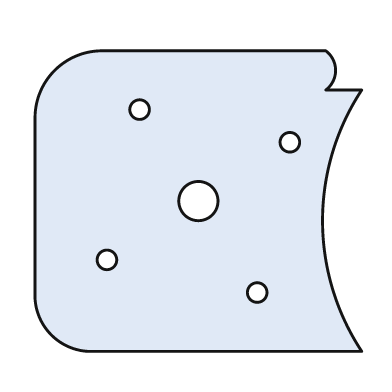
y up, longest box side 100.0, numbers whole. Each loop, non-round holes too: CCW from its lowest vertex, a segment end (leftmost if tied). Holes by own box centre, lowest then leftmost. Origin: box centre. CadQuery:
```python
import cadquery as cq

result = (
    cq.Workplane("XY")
    .moveTo(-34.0, -46.0)
    .lineTo(50.0, -46.0)
    .threePointArc((38.0, -6.0), (50.0, 34.0))
    .lineTo(39.0, 34.0)
    .threePointArc((42.0, 40.0), (39.0, 46.0))
    .lineTo(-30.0, 46.0)
    .threePointArc((-44.0, 40.0), (-50.0, 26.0))
    .lineTo(-50.0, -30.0)
    .threePointArc((-45.0, -41.0), (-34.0, -46.0))
    .close()
    .moveTo(18.0, -28.0)
    .circle(3.0)
    .moveTo(-28.0, -18.0)
    .circle(3.0)
    .moveTo(0.0, 0.0)
    .circle(6.0)
    .moveTo(28.0, 18.0)
    .circle(3.0)
    .moveTo(-18.0, 28.0)
    .circle(3.0)
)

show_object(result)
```